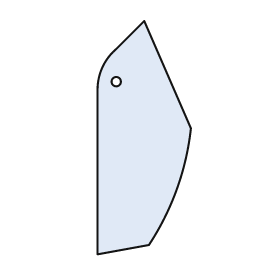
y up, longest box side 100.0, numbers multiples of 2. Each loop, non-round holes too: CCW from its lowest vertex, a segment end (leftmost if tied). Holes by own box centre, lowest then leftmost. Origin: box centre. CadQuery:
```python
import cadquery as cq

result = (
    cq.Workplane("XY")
    .moveTo(-20.0, -50.0)
    .lineTo(2.0, -46.0)
    .threePointArc((14.0, -22.0), (20.0, 4.0))
    .lineTo(0.0, 50.0)
    .lineTo(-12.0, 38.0)
    .threePointArc((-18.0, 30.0), (-20.0, 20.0))
    .close()
    .moveTo(-12.0, 24.0)
    .circle(2.0)
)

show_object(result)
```